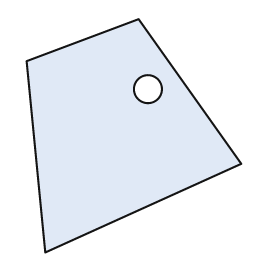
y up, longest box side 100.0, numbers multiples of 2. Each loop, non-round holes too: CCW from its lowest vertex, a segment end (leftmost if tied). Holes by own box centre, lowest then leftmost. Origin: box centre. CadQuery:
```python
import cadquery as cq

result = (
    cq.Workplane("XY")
    .moveTo(-38.0, -50.0)
    .lineTo(46.0, -12.0)
    .lineTo(2.0, 50.0)
    .lineTo(-46.0, 32.0)
    .close()
    .moveTo(6.0, 20.0)
    .circle(6.0)
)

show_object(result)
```